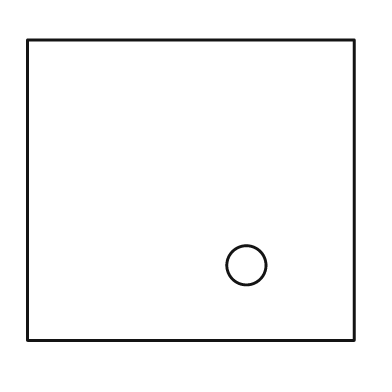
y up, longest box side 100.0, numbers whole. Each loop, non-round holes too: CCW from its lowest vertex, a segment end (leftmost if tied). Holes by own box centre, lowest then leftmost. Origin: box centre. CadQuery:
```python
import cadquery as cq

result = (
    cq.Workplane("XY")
    .moveTo(-50.0, -46.0)
    .lineTo(50.0, -46.0)
    .lineTo(50.0, 46.0)
    .lineTo(-50.0, 46.0)
    .close()
    .moveTo(17.0, -23.0)
    .circle(6.0)
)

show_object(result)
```